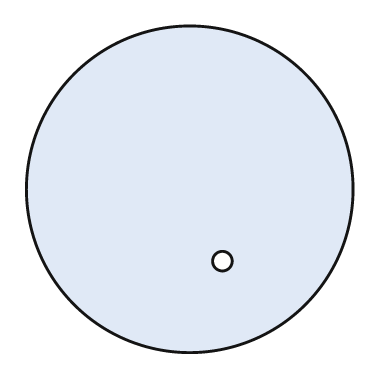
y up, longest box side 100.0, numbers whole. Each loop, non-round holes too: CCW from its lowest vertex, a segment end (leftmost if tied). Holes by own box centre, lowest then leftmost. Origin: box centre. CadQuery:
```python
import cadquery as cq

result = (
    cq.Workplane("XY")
    .moveTo(0.0, 0.0)
    .circle(50.0)
    .moveTo(10.0, -22.0)
    .circle(3.0)
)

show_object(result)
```